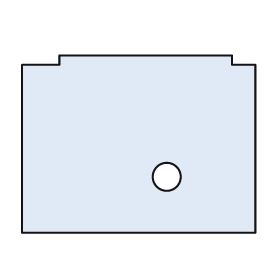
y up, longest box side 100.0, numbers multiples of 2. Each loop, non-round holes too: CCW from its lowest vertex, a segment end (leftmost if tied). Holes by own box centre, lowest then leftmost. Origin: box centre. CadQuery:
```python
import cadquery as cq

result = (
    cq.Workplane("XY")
    .moveTo(-50.0, -38.0)
    .lineTo(50.0, -38.0)
    .lineTo(50.0, 34.0)
    .lineTo(40.0, 34.0)
    .lineTo(40.0, 38.0)
    .lineTo(-34.0, 38.0)
    .lineTo(-34.0, 34.0)
    .lineTo(-50.0, 34.0)
    .close()
    .moveTo(12.0, -14.0)
    .circle(6.0)
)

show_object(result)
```